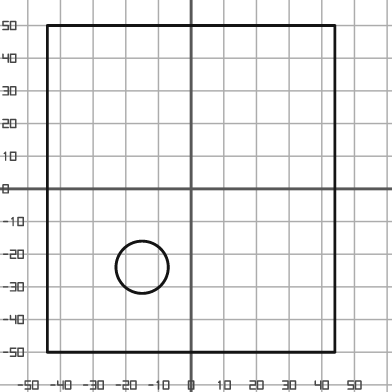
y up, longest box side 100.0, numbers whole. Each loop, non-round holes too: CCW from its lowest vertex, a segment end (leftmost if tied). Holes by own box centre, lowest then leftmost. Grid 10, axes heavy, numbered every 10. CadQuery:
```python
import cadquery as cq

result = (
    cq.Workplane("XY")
    .moveTo(-44.0, -50.0)
    .lineTo(44.0, -50.0)
    .lineTo(44.0, 50.0)
    .lineTo(-44.0, 50.0)
    .close()
    .moveTo(-15.0, -24.0)
    .circle(8.0)
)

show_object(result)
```